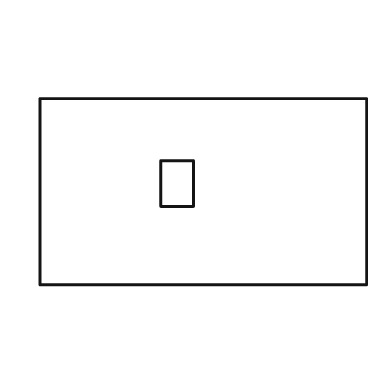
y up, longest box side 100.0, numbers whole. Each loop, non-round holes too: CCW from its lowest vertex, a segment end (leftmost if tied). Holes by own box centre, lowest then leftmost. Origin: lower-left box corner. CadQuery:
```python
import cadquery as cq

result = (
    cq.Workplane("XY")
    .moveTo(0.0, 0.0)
    .lineTo(100.0, 0.0)
    .lineTo(100.0, 57.0)
    .lineTo(0.0, 57.0)
    .close()
    .moveTo(37.0, 24.0)
    .lineTo(47.0, 24.0)
    .lineTo(47.0, 38.0)
    .lineTo(37.0, 38.0)
    .close()
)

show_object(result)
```